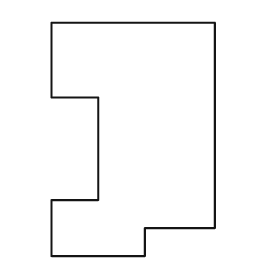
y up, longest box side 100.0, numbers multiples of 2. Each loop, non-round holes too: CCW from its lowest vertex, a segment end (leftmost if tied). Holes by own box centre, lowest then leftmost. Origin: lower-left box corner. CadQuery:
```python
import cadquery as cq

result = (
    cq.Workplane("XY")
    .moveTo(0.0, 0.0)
    .lineTo(40.0, 0.0)
    .lineTo(40.0, 12.0)
    .lineTo(70.0, 12.0)
    .lineTo(70.0, 100.0)
    .lineTo(0.0, 100.0)
    .lineTo(0.0, 68.0)
    .lineTo(20.0, 68.0)
    .lineTo(20.0, 24.0)
    .lineTo(0.0, 24.0)
    .close()
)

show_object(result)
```